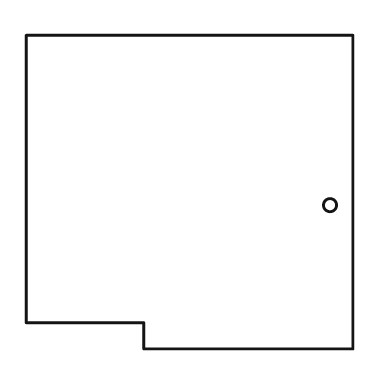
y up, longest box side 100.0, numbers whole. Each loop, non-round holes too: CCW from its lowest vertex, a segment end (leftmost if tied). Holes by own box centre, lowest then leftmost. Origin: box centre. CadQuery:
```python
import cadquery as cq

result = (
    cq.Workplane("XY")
    .moveTo(-14.0, -48.0)
    .lineTo(50.0, -48.0)
    .lineTo(50.0, 48.0)
    .lineTo(-50.0, 48.0)
    .lineTo(-50.0, -40.0)
    .lineTo(-14.0, -40.0)
    .close()
    .moveTo(43.0, -4.0)
    .circle(2.0)
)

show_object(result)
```